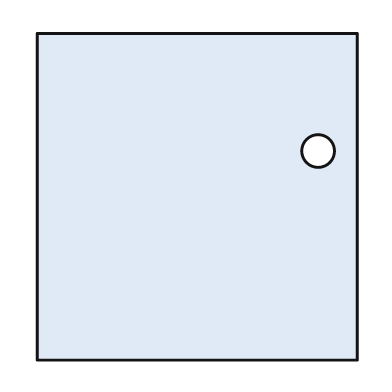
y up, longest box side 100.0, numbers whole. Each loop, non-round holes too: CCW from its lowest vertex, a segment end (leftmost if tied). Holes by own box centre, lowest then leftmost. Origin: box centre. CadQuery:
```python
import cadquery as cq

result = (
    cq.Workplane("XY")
    .moveTo(-49.0, -50.0)
    .lineTo(49.0, -50.0)
    .lineTo(49.0, 50.0)
    .lineTo(-49.0, 50.0)
    .close()
    .moveTo(37.0, 14.0)
    .circle(5.0)
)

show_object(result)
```